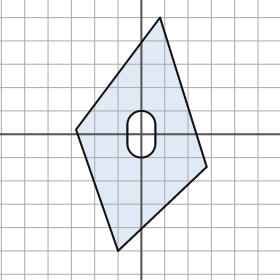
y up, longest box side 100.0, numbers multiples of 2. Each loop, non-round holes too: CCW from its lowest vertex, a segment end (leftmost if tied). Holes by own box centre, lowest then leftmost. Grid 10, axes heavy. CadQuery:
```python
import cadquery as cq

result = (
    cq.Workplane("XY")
    .moveTo(-10.0, -50.0)
    .lineTo(28.0, -14.0)
    .lineTo(8.0, 50.0)
    .lineTo(-28.0, 2.0)
    .close()
    .moveTo(-6.0, -4.0)
    .threePointArc((0.0, -10.0), (6.0, -4.0))
    .lineTo(6.0, 4.0)
    .threePointArc((0.0, 10.0), (-6.0, 4.0))
    .close()
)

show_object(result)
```